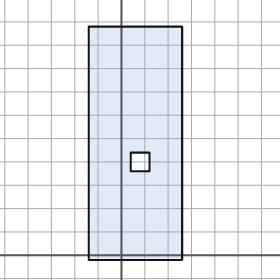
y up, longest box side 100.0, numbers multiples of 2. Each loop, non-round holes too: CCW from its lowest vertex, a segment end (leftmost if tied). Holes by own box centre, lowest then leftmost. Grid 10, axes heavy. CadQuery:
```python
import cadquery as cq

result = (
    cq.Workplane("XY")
    .moveTo(-14.0, -2.0)
    .lineTo(26.0, -2.0)
    .lineTo(26.0, 98.0)
    .lineTo(-14.0, 98.0)
    .close()
    .moveTo(4.0, 36.0)
    .lineTo(12.0, 36.0)
    .lineTo(12.0, 44.0)
    .lineTo(4.0, 44.0)
    .close()
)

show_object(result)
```